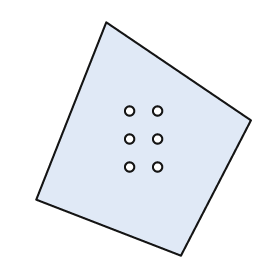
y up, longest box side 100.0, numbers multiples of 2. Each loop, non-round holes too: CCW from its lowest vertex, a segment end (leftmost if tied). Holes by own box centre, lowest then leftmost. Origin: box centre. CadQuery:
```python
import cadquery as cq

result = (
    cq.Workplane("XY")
    .moveTo(16.0, -50.0)
    .lineTo(46.0, 8.0)
    .lineTo(-16.0, 50.0)
    .lineTo(-46.0, -26.0)
    .close()
    .moveTo(-6.0, -12.0)
    .circle(2.0)
    .moveTo(6.0, -12.0)
    .circle(2.0)
    .moveTo(-6.0, 0.0)
    .circle(2.0)
    .moveTo(6.0, 0.0)
    .circle(2.0)
    .moveTo(-6.0, 12.0)
    .circle(2.0)
    .moveTo(6.0, 12.0)
    .circle(2.0)
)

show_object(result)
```